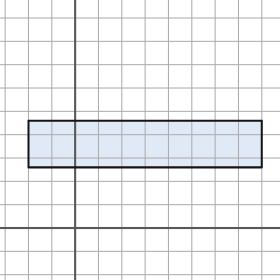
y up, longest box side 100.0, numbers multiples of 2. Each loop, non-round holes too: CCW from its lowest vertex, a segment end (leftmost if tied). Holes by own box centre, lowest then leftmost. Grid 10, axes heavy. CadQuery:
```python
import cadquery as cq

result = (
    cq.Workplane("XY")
    .moveTo(-20.0, 26.0)
    .lineTo(80.0, 26.0)
    .lineTo(80.0, 46.0)
    .lineTo(-20.0, 46.0)
    .close()
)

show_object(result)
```